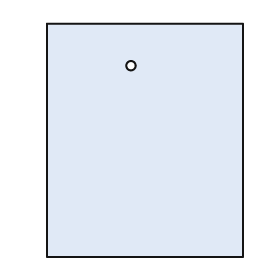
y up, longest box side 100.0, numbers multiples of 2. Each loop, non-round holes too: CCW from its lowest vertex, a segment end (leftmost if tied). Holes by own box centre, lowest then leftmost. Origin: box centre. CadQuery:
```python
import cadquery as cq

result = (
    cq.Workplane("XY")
    .moveTo(-42.0, -50.0)
    .lineTo(42.0, -50.0)
    .lineTo(42.0, 50.0)
    .lineTo(-42.0, 50.0)
    .close()
    .moveTo(-6.0, 32.0)
    .circle(2.0)
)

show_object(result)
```